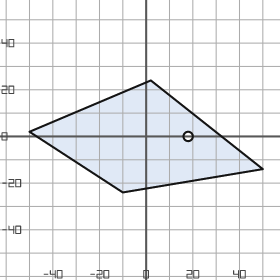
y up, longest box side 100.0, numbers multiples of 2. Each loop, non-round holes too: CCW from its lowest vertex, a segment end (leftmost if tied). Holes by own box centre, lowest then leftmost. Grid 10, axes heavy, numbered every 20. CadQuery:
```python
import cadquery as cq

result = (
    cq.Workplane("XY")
    .moveTo(-10.0, -24.0)
    .lineTo(50.0, -14.0)
    .lineTo(2.0, 24.0)
    .lineTo(-50.0, 2.0)
    .close()
    .moveTo(18.0, 0.0)
    .circle(2.0)
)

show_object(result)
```